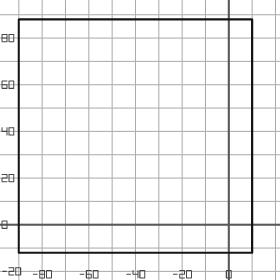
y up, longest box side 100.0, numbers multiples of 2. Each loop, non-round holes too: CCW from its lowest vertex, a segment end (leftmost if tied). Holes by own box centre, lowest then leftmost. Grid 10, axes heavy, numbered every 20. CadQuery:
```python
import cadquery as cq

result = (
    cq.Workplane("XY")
    .moveTo(-90.0, -12.0)
    .lineTo(10.0, -12.0)
    .lineTo(10.0, 88.0)
    .lineTo(-90.0, 88.0)
    .close()
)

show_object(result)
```